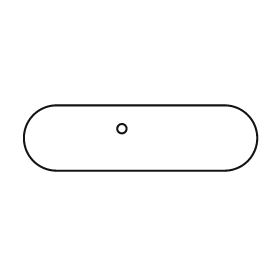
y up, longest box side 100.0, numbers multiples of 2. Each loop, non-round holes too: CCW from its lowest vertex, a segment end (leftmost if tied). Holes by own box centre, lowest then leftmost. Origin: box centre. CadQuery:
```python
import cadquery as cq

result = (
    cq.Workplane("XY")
    .moveTo(-36.0, -14.0)
    .lineTo(36.0, -14.0)
    .threePointArc((50.0, 0.0), (36.0, 14.0))
    .lineTo(-36.0, 14.0)
    .threePointArc((-50.0, 0.0), (-36.0, -14.0))
    .close()
    .moveTo(-8.0, 4.0)
    .circle(2.0)
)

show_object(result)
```